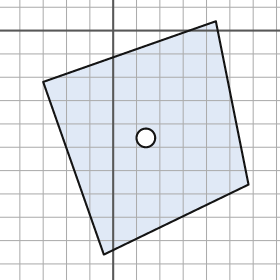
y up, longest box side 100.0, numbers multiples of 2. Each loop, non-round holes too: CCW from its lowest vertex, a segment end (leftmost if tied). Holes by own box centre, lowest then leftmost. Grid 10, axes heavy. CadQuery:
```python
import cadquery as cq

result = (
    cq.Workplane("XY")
    .moveTo(-4.0, -96.0)
    .lineTo(58.0, -66.0)
    .lineTo(44.0, 4.0)
    .lineTo(-30.0, -22.0)
    .close()
    .moveTo(14.0, -46.0)
    .circle(4.0)
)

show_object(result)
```